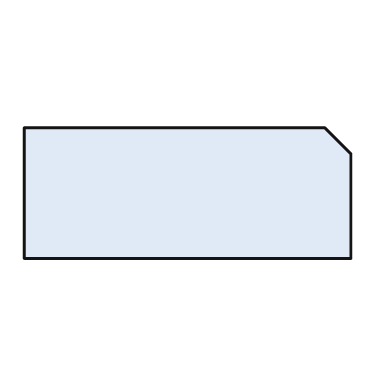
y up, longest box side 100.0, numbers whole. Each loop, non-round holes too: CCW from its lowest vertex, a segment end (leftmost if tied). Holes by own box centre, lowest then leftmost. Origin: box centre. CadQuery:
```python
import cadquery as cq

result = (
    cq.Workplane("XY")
    .moveTo(-50.0, -20.0)
    .lineTo(50.0, -20.0)
    .lineTo(50.0, 12.0)
    .lineTo(42.0, 20.0)
    .lineTo(-50.0, 20.0)
    .close()
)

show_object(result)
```